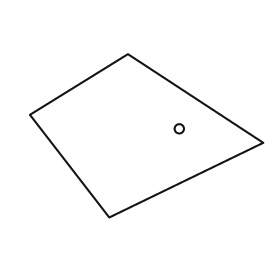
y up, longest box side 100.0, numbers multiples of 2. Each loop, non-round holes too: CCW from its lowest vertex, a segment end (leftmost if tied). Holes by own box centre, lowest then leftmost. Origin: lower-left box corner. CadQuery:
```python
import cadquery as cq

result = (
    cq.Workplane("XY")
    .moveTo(34.0, 0.0)
    .lineTo(100.0, 32.0)
    .lineTo(42.0, 70.0)
    .lineTo(0.0, 44.0)
    .close()
    .moveTo(64.0, 38.0)
    .circle(2.0)
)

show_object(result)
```